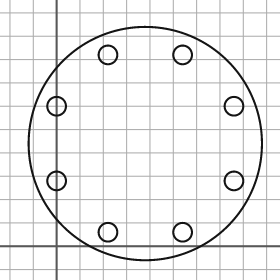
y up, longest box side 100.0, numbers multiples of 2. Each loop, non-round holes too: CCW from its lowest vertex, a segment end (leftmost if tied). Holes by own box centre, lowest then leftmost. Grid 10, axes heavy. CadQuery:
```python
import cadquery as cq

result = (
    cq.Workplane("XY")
    .moveTo(38.0, 44.0)
    .circle(50.0)
    .moveTo(22.0, 6.0)
    .circle(4.0)
    .moveTo(54.0, 6.0)
    .circle(4.0)
    .moveTo(0.0, 28.0)
    .circle(4.0)
    .moveTo(76.0, 28.0)
    .circle(4.0)
    .moveTo(0.0, 60.0)
    .circle(4.0)
    .moveTo(76.0, 60.0)
    .circle(4.0)
    .moveTo(22.0, 82.0)
    .circle(4.0)
    .moveTo(54.0, 82.0)
    .circle(4.0)
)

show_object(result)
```